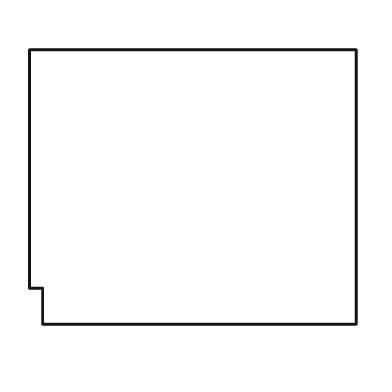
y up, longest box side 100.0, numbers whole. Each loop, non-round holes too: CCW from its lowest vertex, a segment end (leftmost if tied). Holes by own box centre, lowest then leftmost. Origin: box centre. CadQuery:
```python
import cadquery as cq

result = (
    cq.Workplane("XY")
    .moveTo(-46.0, -42.0)
    .lineTo(50.0, -42.0)
    .lineTo(50.0, 42.0)
    .lineTo(-50.0, 42.0)
    .lineTo(-50.0, -31.0)
    .lineTo(-46.0, -31.0)
    .close()
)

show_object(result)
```